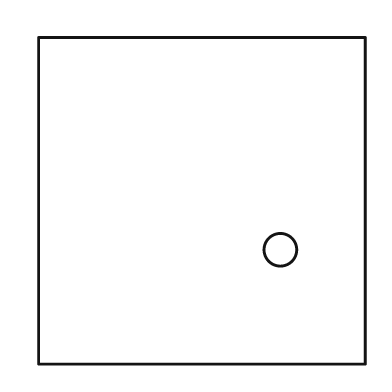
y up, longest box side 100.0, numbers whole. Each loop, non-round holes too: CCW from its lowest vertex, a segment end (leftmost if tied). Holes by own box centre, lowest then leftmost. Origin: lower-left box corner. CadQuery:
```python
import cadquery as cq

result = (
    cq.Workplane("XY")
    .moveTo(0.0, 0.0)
    .lineTo(100.0, 0.0)
    .lineTo(100.0, 100.0)
    .lineTo(0.0, 100.0)
    .close()
    .moveTo(74.0, 35.0)
    .circle(5.0)
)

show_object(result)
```